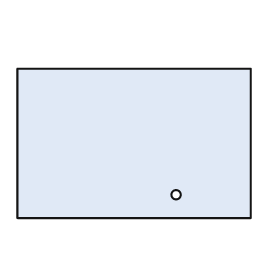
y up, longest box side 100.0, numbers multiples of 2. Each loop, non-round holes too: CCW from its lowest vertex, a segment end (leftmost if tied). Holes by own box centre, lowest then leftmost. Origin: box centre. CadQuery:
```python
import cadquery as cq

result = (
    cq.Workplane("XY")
    .moveTo(-50.0, -32.0)
    .lineTo(50.0, -32.0)
    .lineTo(50.0, 32.0)
    .lineTo(-50.0, 32.0)
    .close()
    .moveTo(18.0, -22.0)
    .circle(2.0)
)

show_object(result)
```